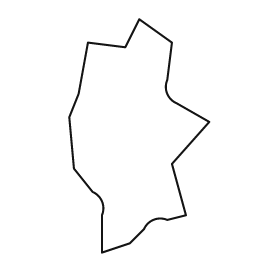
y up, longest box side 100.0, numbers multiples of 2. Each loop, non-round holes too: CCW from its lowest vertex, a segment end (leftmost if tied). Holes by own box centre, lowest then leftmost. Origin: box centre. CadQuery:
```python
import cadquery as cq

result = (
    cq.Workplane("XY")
    .moveTo(-16.0, -50.0)
    .lineTo(-4.0, -46.0)
    .lineTo(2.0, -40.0)
    .threePointArc((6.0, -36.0), (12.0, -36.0))
    .lineTo(20.0, -34.0)
    .lineTo(14.0, -12.0)
    .lineTo(30.0, 6.0)
    .lineTo(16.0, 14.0)
    .threePointArc((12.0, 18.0), (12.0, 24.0))
    .lineTo(14.0, 40.0)
    .lineTo(0.0, 50.0)
    .lineTo(-6.0, 38.0)
    .lineTo(-22.0, 40.0)
    .lineTo(-26.0, 18.0)
    .lineTo(-30.0, 8.0)
    .lineTo(-28.0, -14.0)
    .lineTo(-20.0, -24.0)
    .threePointArc((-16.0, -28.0), (-16.0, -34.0))
    .close()
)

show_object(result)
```